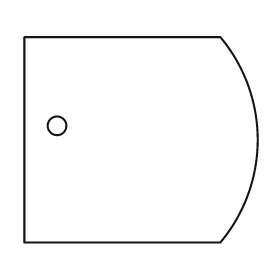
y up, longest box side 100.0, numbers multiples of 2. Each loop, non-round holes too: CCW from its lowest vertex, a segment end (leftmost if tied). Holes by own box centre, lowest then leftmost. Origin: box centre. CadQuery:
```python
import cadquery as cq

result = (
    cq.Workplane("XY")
    .moveTo(-50.0, -44.0)
    .lineTo(34.0, -44.0)
    .threePointArc((50.0, 0.0), (34.0, 44.0))
    .lineTo(-50.0, 44.0)
    .close()
    .moveTo(-36.0, 6.0)
    .circle(4.0)
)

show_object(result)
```